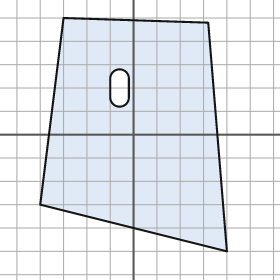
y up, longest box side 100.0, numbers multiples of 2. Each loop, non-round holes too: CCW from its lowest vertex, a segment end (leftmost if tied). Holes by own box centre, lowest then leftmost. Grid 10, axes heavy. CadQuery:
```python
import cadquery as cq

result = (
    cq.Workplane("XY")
    .moveTo(40.0, -50.0)
    .lineTo(32.0, 48.0)
    .lineTo(-30.0, 50.0)
    .lineTo(-40.0, -30.0)
    .close()
    .moveTo(-10.0, 16.0)
    .threePointArc((-6.0, 12.0), (-2.0, 16.0))
    .lineTo(-2.0, 24.0)
    .threePointArc((-6.0, 28.0), (-10.0, 24.0))
    .close()
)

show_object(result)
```